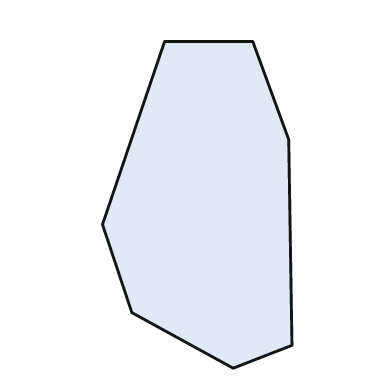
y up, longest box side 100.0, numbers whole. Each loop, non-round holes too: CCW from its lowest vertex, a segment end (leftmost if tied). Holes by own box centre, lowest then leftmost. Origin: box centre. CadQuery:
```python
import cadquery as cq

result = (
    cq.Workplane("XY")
    .moveTo(11.0, -50.0)
    .lineTo(29.0, -43.0)
    .lineTo(28.0, 20.0)
    .lineTo(17.0, 50.0)
    .lineTo(-10.0, 50.0)
    .lineTo(-29.0, -6.0)
    .lineTo(-20.0, -33.0)
    .close()
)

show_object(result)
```